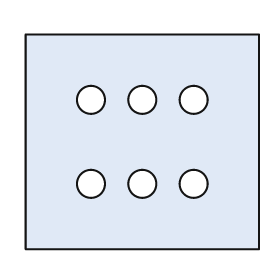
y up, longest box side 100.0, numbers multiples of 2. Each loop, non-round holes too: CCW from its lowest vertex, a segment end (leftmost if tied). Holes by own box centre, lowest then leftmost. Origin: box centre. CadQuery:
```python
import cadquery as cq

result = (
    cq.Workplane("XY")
    .moveTo(-50.0, -46.0)
    .lineTo(50.0, -46.0)
    .lineTo(50.0, 46.0)
    .lineTo(-50.0, 46.0)
    .close()
    .moveTo(-22.0, -18.0)
    .circle(6.0)
    .moveTo(0.0, -18.0)
    .circle(6.0)
    .moveTo(22.0, -18.0)
    .circle(6.0)
    .moveTo(-22.0, 18.0)
    .circle(6.0)
    .moveTo(0.0, 18.0)
    .circle(6.0)
    .moveTo(22.0, 18.0)
    .circle(6.0)
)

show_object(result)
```